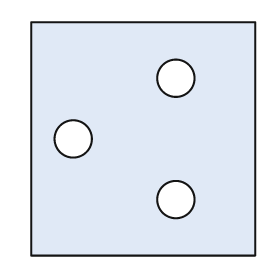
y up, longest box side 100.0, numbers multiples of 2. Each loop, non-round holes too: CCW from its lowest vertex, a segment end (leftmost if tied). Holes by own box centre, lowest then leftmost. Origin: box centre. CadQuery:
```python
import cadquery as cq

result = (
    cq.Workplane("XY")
    .moveTo(-48.0, -50.0)
    .lineTo(48.0, -50.0)
    .lineTo(48.0, 50.0)
    .lineTo(-48.0, 50.0)
    .close()
    .moveTo(14.0, -26.0)
    .circle(8.0)
    .moveTo(-30.0, 0.0)
    .circle(8.0)
    .moveTo(14.0, 26.0)
    .circle(8.0)
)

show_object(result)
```